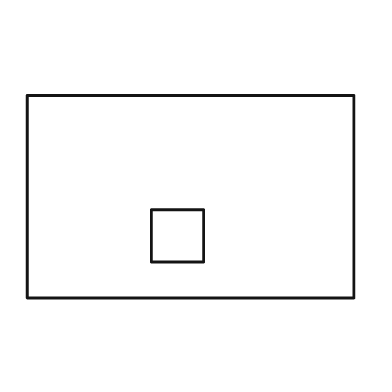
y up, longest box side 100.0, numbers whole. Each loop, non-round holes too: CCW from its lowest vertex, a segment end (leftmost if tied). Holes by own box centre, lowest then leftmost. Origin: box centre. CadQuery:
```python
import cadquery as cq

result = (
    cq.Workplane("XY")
    .moveTo(-50.0, -31.0)
    .lineTo(50.0, -31.0)
    .lineTo(50.0, 31.0)
    .lineTo(-50.0, 31.0)
    .close()
    .moveTo(-12.0, -20.0)
    .lineTo(4.0, -20.0)
    .lineTo(4.0, -4.0)
    .lineTo(-12.0, -4.0)
    .close()
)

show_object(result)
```